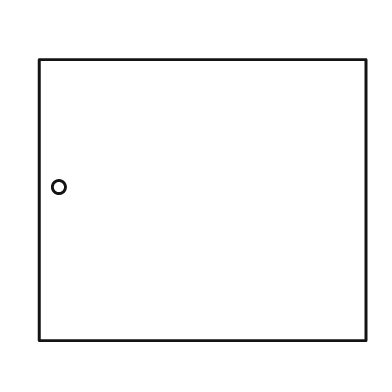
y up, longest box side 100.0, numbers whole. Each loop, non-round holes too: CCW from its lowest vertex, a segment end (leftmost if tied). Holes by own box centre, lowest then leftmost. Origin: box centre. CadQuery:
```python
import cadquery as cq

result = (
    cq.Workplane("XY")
    .moveTo(-50.0, -43.0)
    .lineTo(50.0, -43.0)
    .lineTo(50.0, 43.0)
    .lineTo(-50.0, 43.0)
    .close()
    .moveTo(-44.0, 4.0)
    .circle(2.0)
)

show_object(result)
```